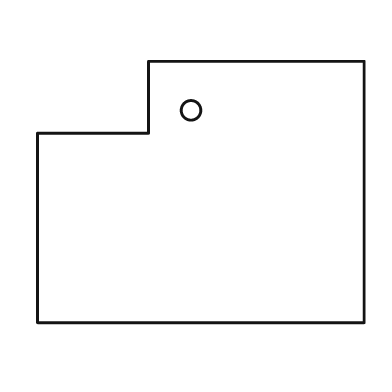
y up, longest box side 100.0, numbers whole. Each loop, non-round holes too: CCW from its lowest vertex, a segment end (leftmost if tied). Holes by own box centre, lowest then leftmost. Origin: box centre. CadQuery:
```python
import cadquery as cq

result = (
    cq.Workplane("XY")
    .moveTo(-50.0, -40.0)
    .lineTo(50.0, -40.0)
    .lineTo(50.0, 40.0)
    .lineTo(-16.0, 40.0)
    .lineTo(-16.0, 18.0)
    .lineTo(-50.0, 18.0)
    .close()
    .moveTo(-3.0, 25.0)
    .circle(3.0)
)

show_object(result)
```